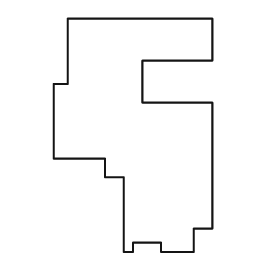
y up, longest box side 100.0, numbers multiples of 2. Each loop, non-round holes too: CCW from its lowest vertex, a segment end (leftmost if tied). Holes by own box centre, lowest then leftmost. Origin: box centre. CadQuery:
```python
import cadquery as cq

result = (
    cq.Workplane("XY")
    .moveTo(-4.0, -50.0)
    .lineTo(0.0, -50.0)
    .lineTo(0.0, -46.0)
    .lineTo(12.0, -46.0)
    .lineTo(12.0, -50.0)
    .lineTo(26.0, -50.0)
    .lineTo(26.0, -40.0)
    .lineTo(34.0, -40.0)
    .lineTo(34.0, 14.0)
    .lineTo(4.0, 14.0)
    .lineTo(4.0, 32.0)
    .lineTo(34.0, 32.0)
    .lineTo(34.0, 50.0)
    .lineTo(-28.0, 50.0)
    .lineTo(-28.0, 22.0)
    .lineTo(-34.0, 22.0)
    .lineTo(-34.0, -10.0)
    .lineTo(-12.0, -10.0)
    .lineTo(-12.0, -18.0)
    .lineTo(-4.0, -18.0)
    .close()
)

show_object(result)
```